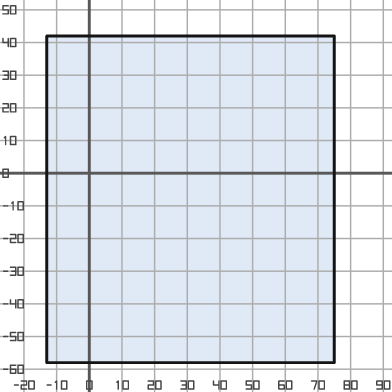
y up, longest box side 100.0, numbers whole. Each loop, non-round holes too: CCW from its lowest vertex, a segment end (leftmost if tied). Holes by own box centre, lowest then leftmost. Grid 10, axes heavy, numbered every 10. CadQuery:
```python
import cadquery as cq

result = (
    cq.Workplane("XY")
    .moveTo(-13.0, -58.0)
    .lineTo(75.0, -58.0)
    .lineTo(75.0, 42.0)
    .lineTo(-13.0, 42.0)
    .close()
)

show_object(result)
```